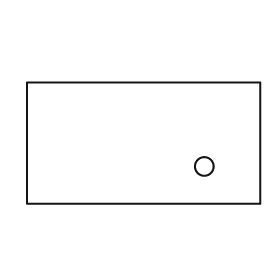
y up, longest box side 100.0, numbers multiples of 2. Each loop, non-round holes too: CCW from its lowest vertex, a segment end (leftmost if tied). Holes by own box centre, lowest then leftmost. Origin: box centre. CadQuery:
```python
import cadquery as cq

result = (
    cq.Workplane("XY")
    .moveTo(-50.0, -26.0)
    .lineTo(50.0, -26.0)
    .lineTo(50.0, 26.0)
    .lineTo(-50.0, 26.0)
    .close()
    .moveTo(26.0, -10.0)
    .circle(4.0)
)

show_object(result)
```